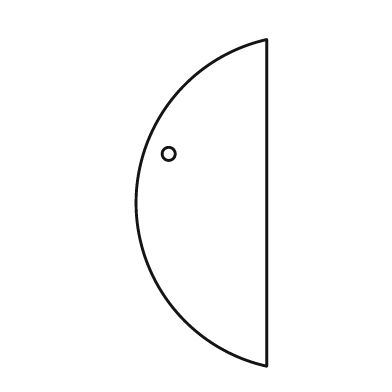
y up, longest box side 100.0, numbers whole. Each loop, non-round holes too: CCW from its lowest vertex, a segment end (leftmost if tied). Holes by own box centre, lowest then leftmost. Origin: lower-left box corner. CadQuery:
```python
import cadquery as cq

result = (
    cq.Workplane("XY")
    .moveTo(40.0, 0.0)
    .lineTo(40.0, 100.0)
    .threePointArc((0.0, 50.0), (40.0, 0.0))
    .close()
    .moveTo(10.0, 65.0)
    .circle(2.0)
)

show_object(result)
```